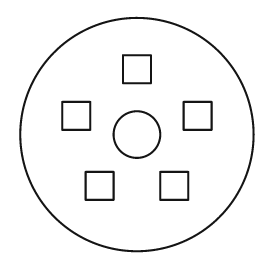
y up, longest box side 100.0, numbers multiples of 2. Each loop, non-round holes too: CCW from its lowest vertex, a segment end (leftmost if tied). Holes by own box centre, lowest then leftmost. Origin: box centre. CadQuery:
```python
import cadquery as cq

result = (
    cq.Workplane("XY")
    .moveTo(0.0, 0.0)
    .circle(50.0)
    .moveTo(-22.0, -28.0)
    .lineTo(-10.0, -28.0)
    .lineTo(-10.0, -16.0)
    .lineTo(-22.0, -16.0)
    .close()
    .moveTo(10.0, -28.0)
    .lineTo(22.0, -28.0)
    .lineTo(22.0, -16.0)
    .lineTo(10.0, -16.0)
    .close()
    .moveTo(0.0, 0.0)
    .circle(10.0)
    .moveTo(-32.0, 2.0)
    .lineTo(-20.0, 2.0)
    .lineTo(-20.0, 14.0)
    .lineTo(-32.0, 14.0)
    .close()
    .moveTo(20.0, 2.0)
    .lineTo(32.0, 2.0)
    .lineTo(32.0, 14.0)
    .lineTo(20.0, 14.0)
    .close()
    .moveTo(-6.0, 22.0)
    .lineTo(6.0, 22.0)
    .lineTo(6.0, 34.0)
    .lineTo(-6.0, 34.0)
    .close()
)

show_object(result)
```